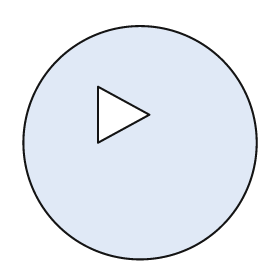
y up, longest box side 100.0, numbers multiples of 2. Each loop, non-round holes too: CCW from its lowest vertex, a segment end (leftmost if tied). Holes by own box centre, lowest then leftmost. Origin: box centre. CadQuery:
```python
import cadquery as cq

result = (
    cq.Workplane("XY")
    .moveTo(0.0, 0.0)
    .circle(50.0)
    .moveTo(-18.0, 0.0)
    .lineTo(4.0, 12.0)
    .lineTo(-18.0, 24.0)
    .close()
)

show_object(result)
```